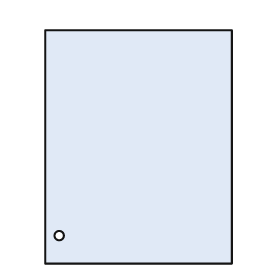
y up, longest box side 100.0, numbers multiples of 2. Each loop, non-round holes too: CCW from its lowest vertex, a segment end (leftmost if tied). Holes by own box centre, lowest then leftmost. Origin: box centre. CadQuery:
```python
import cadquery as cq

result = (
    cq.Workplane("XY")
    .moveTo(-40.0, -50.0)
    .lineTo(40.0, -50.0)
    .lineTo(40.0, 50.0)
    .lineTo(-40.0, 50.0)
    .close()
    .moveTo(-34.0, -38.0)
    .circle(2.0)
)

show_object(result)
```